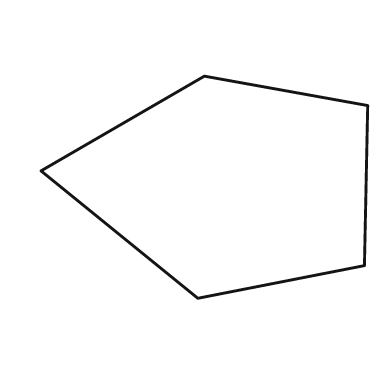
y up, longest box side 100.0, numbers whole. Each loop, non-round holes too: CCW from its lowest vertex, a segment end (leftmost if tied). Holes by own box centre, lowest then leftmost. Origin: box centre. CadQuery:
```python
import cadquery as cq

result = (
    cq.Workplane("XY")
    .moveTo(-2.0, -34.0)
    .lineTo(49.0, -24.0)
    .lineTo(50.0, 25.0)
    .lineTo(0.0, 34.0)
    .lineTo(-50.0, 5.0)
    .close()
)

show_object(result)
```